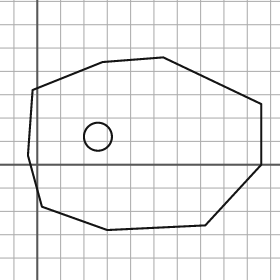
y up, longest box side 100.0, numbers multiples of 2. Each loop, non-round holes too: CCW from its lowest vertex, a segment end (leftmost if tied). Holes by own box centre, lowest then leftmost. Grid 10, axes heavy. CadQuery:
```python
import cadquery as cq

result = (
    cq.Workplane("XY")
    .moveTo(30.0, -28.0)
    .lineTo(72.0, -26.0)
    .lineTo(96.0, 0.0)
    .lineTo(96.0, 26.0)
    .lineTo(54.0, 46.0)
    .lineTo(28.0, 44.0)
    .lineTo(-2.0, 32.0)
    .lineTo(-4.0, 4.0)
    .lineTo(2.0, -18.0)
    .close()
    .moveTo(26.0, 12.0)
    .circle(6.0)
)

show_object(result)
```